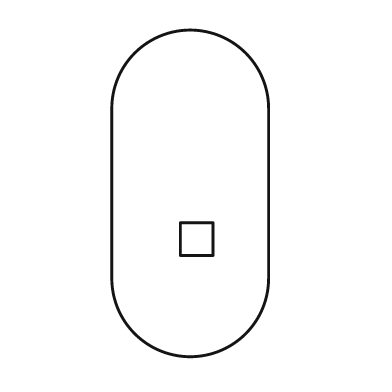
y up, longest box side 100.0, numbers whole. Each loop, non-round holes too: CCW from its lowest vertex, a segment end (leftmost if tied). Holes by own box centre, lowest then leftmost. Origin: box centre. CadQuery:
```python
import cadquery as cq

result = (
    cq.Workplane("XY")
    .moveTo(-24.0, -26.0)
    .threePointArc((0.0, -50.0), (24.0, -26.0))
    .lineTo(24.0, 26.0)
    .threePointArc((0.0, 50.0), (-24.0, 26.0))
    .close()
    .moveTo(-3.0, -19.0)
    .lineTo(7.0, -19.0)
    .lineTo(7.0, -9.0)
    .lineTo(-3.0, -9.0)
    .close()
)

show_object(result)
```